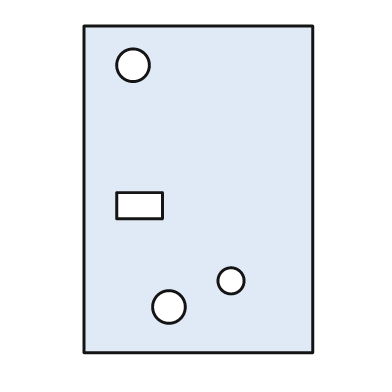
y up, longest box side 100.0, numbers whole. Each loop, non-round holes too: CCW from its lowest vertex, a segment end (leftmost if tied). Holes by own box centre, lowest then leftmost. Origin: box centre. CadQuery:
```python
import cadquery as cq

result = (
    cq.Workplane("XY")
    .moveTo(-35.0, -50.0)
    .lineTo(35.0, -50.0)
    .lineTo(35.0, 50.0)
    .lineTo(-35.0, 50.0)
    .close()
    .moveTo(-9.0, -36.0)
    .circle(5.0)
    .moveTo(10.0, -28.0)
    .circle(4.0)
    .moveTo(-25.0, -9.0)
    .lineTo(-11.0, -9.0)
    .lineTo(-11.0, -1.0)
    .lineTo(-25.0, -1.0)
    .close()
    .moveTo(-20.0, 38.0)
    .circle(5.0)
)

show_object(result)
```